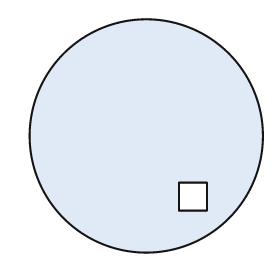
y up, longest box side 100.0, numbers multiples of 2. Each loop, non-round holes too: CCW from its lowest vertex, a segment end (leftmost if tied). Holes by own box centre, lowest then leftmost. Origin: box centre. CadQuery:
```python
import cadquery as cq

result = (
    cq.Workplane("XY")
    .moveTo(0.0, 0.0)
    .circle(50.0)
    .moveTo(14.0, -32.0)
    .lineTo(26.0, -32.0)
    .lineTo(26.0, -20.0)
    .lineTo(14.0, -20.0)
    .close()
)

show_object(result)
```